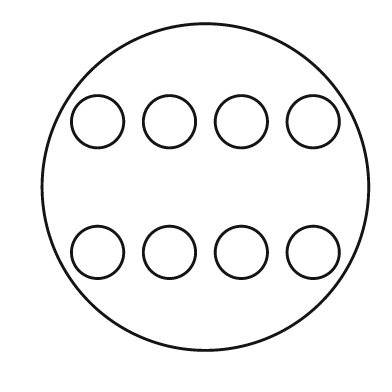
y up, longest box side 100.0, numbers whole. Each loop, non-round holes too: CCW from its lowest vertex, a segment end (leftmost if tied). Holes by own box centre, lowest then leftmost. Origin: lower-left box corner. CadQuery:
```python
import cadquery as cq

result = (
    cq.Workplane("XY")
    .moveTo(50.0, 50.0)
    .circle(50.0)
    .moveTo(17.0, 30.0)
    .circle(8.0)
    .moveTo(39.0, 30.0)
    .circle(8.0)
    .moveTo(61.0, 30.0)
    .circle(8.0)
    .moveTo(83.0, 30.0)
    .circle(8.0)
    .moveTo(17.0, 70.0)
    .circle(8.0)
    .moveTo(39.0, 70.0)
    .circle(8.0)
    .moveTo(61.0, 70.0)
    .circle(8.0)
    .moveTo(83.0, 70.0)
    .circle(8.0)
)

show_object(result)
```